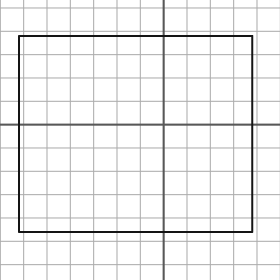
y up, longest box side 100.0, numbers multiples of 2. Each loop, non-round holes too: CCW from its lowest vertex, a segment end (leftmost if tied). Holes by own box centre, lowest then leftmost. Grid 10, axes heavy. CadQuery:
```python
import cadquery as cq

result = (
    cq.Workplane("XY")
    .moveTo(-62.0, -46.0)
    .lineTo(38.0, -46.0)
    .lineTo(38.0, 38.0)
    .lineTo(-62.0, 38.0)
    .close()
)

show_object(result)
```